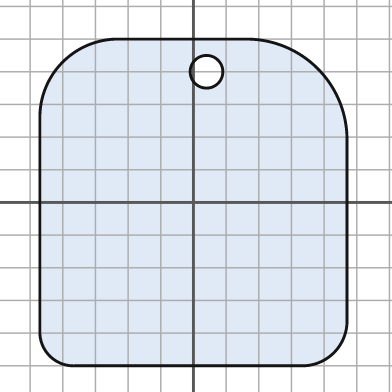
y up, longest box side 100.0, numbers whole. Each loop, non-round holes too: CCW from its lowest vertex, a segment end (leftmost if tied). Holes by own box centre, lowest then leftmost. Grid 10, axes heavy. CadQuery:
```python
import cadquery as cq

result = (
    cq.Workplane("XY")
    .moveTo(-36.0, -50.0)
    .lineTo(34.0, -50.0)
    .threePointArc((43.0, -46.0), (47.0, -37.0))
    .lineTo(47.0, 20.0)
    .threePointArc((38.0, 41.0), (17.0, 50.0))
    .lineTo(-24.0, 50.0)
    .threePointArc((-40.0, 43.0), (-47.0, 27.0))
    .lineTo(-47.0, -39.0)
    .threePointArc((-44.0, -47.0), (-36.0, -50.0))
    .close()
    .moveTo(4.0, 40.0)
    .circle(5.0)
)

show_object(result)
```